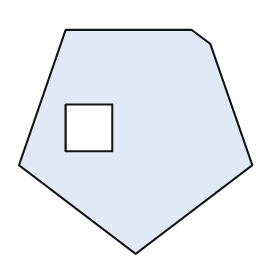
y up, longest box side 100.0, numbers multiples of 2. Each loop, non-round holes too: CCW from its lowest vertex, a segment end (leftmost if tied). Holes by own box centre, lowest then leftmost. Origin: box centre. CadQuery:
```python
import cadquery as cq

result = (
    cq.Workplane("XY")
    .moveTo(0.0, -48.0)
    .lineTo(50.0, -10.0)
    .lineTo(32.0, 42.0)
    .lineTo(24.0, 48.0)
    .lineTo(-30.0, 48.0)
    .lineTo(-50.0, -10.0)
    .close()
    .moveTo(-30.0, -4.0)
    .lineTo(-10.0, -4.0)
    .lineTo(-10.0, 16.0)
    .lineTo(-30.0, 16.0)
    .close()
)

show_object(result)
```